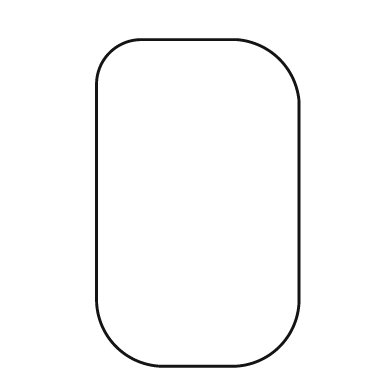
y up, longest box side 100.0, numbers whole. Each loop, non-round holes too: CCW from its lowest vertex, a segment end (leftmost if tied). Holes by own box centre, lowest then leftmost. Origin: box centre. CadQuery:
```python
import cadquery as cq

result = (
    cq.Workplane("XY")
    .moveTo(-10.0, -50.0)
    .lineTo(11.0, -50.0)
    .threePointArc((25.0, -44.0), (31.0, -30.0))
    .lineTo(31.0, 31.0)
    .threePointArc((25.0, 44.0), (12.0, 50.0))
    .lineTo(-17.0, 50.0)
    .threePointArc((-27.0, 46.0), (-31.0, 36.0))
    .lineTo(-31.0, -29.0)
    .threePointArc((-25.0, -44.0), (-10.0, -50.0))
    .close()
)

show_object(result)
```